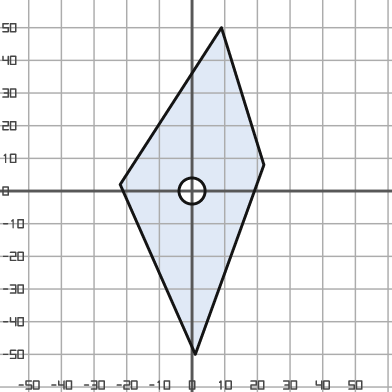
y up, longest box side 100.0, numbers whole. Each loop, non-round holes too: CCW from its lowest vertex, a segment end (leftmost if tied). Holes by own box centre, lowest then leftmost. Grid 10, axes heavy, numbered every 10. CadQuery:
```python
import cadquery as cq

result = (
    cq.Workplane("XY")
    .moveTo(1.0, -50.0)
    .lineTo(22.0, 8.0)
    .lineTo(9.0, 50.0)
    .lineTo(-22.0, 2.0)
    .close()
    .moveTo(0.0, 0.0)
    .circle(4.0)
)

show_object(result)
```